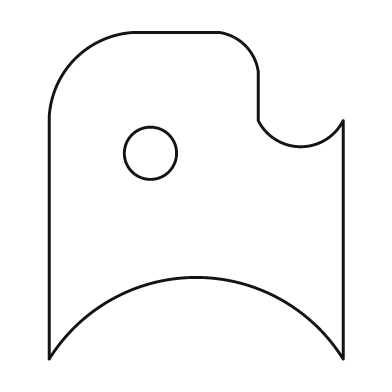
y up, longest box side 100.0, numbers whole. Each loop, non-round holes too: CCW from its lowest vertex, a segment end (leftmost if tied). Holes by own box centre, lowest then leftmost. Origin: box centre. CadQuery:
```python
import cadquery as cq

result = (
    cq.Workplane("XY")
    .moveTo(-45.0, -50.0)
    .threePointArc((0.0, -25.0), (45.0, -50.0))
    .lineTo(45.0, 23.0)
    .threePointArc((32.0, 15.0), (19.0, 23.0))
    .lineTo(19.0, 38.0)
    .threePointArc((15.0, 46.0), (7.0, 50.0))
    .lineTo(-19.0, 50.0)
    .threePointArc((-37.0, 42.0), (-45.0, 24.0))
    .close()
    .moveTo(-14.0, 13.0)
    .circle(8.0)
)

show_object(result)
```